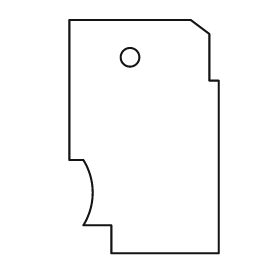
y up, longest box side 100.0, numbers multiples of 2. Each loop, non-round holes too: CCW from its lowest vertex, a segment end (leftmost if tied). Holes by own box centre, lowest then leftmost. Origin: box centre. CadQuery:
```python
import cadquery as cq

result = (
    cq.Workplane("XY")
    .moveTo(-14.0, -50.0)
    .lineTo(32.0, -50.0)
    .lineTo(32.0, 24.0)
    .lineTo(28.0, 24.0)
    .lineTo(28.0, 44.0)
    .lineTo(20.0, 50.0)
    .lineTo(-32.0, 50.0)
    .lineTo(-32.0, -10.0)
    .lineTo(-26.0, -10.0)
    .threePointArc((-22.0, -24.0), (-26.0, -38.0))
    .lineTo(-14.0, -38.0)
    .close()
    .moveTo(-6.0, 34.0)
    .circle(4.0)
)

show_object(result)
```